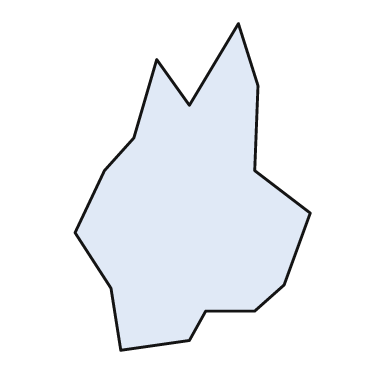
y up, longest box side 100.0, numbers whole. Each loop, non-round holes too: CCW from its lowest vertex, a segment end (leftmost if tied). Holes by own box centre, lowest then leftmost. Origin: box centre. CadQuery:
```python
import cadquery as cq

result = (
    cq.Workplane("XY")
    .moveTo(-22.0, -50.0)
    .lineTo(-1.0, -47.0)
    .lineTo(4.0, -38.0)
    .lineTo(19.0, -38.0)
    .lineTo(28.0, -30.0)
    .lineTo(36.0, -8.0)
    .lineTo(19.0, 5.0)
    .lineTo(20.0, 31.0)
    .lineTo(14.0, 50.0)
    .lineTo(-1.0, 25.0)
    .lineTo(-11.0, 39.0)
    .lineTo(-18.0, 15.0)
    .lineTo(-27.0, 5.0)
    .lineTo(-36.0, -14.0)
    .lineTo(-25.0, -31.0)
    .close()
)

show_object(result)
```